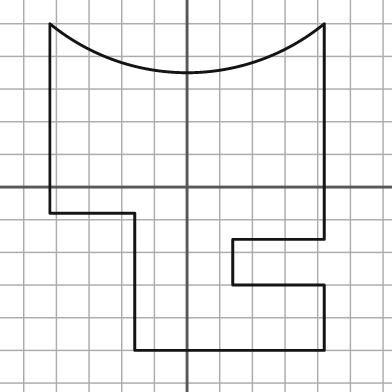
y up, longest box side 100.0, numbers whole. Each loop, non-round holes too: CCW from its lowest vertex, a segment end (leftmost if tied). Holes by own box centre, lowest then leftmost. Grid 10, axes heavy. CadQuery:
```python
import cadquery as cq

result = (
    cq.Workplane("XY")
    .moveTo(-16.0, -50.0)
    .lineTo(42.0, -50.0)
    .lineTo(42.0, -30.0)
    .lineTo(14.0, -30.0)
    .lineTo(14.0, -16.0)
    .lineTo(42.0, -16.0)
    .lineTo(42.0, 50.0)
    .threePointArc((0.0, 35.0), (-42.0, 50.0))
    .lineTo(-42.0, -8.0)
    .lineTo(-16.0, -8.0)
    .close()
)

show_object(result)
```